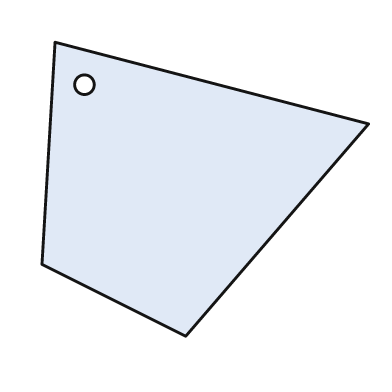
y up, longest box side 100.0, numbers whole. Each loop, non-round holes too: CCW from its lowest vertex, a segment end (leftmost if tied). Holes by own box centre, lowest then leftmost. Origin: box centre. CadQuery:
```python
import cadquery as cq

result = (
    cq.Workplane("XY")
    .moveTo(-6.0, -45.0)
    .lineTo(50.0, 20.0)
    .lineTo(-46.0, 45.0)
    .lineTo(-50.0, -23.0)
    .close()
    .moveTo(-37.0, 32.0)
    .circle(3.0)
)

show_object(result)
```